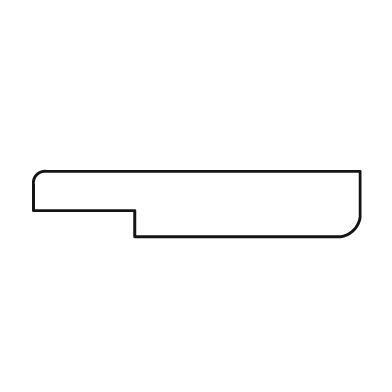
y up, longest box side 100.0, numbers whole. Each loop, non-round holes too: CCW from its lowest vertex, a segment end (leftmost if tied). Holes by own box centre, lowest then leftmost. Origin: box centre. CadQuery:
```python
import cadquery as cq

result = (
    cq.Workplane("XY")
    .moveTo(-19.0, -10.0)
    .lineTo(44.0, -10.0)
    .threePointArc((48.0, -8.0), (50.0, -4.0))
    .lineTo(50.0, 10.0)
    .lineTo(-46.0, 10.0)
    .threePointArc((-49.0, 9.0), (-50.0, 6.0))
    .lineTo(-50.0, -2.0)
    .lineTo(-19.0, -2.0)
    .close()
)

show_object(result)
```